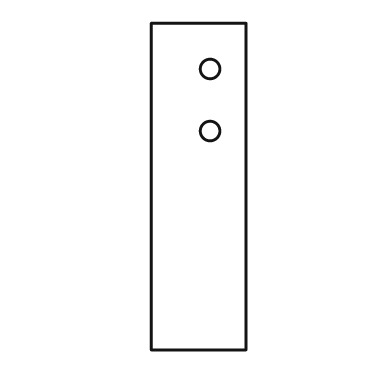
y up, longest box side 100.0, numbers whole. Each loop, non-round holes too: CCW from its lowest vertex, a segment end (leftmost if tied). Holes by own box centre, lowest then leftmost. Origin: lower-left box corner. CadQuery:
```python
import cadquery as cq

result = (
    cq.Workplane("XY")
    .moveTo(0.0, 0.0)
    .lineTo(29.0, 0.0)
    .lineTo(29.0, 100.0)
    .lineTo(0.0, 100.0)
    .close()
    .moveTo(18.0, 67.0)
    .circle(3.0)
    .moveTo(18.0, 86.0)
    .circle(3.0)
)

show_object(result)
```